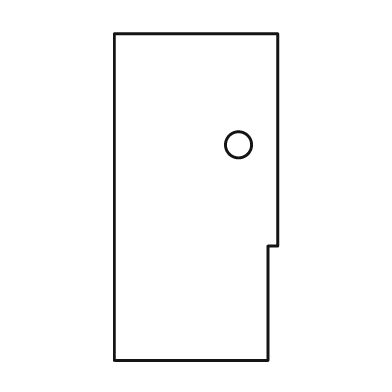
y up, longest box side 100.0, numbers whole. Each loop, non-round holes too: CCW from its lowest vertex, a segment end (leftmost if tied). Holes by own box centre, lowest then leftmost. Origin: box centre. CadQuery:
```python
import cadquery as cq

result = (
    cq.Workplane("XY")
    .moveTo(-25.0, -50.0)
    .lineTo(22.0, -50.0)
    .lineTo(22.0, -15.0)
    .lineTo(25.0, -15.0)
    .lineTo(25.0, 50.0)
    .lineTo(-25.0, 50.0)
    .close()
    .moveTo(13.0, 16.0)
    .circle(4.0)
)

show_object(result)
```